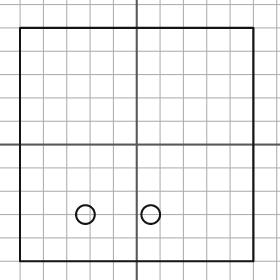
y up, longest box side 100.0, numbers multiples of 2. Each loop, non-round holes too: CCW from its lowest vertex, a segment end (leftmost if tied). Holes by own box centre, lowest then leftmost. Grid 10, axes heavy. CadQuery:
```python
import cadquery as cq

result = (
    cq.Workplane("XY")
    .moveTo(-50.0, -50.0)
    .lineTo(50.0, -50.0)
    .lineTo(50.0, 50.0)
    .lineTo(-50.0, 50.0)
    .close()
    .moveTo(-22.0, -30.0)
    .circle(4.0)
    .moveTo(6.0, -30.0)
    .circle(4.0)
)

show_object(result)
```